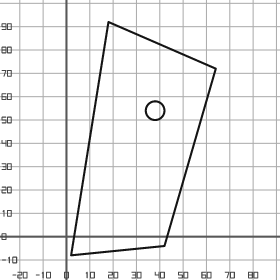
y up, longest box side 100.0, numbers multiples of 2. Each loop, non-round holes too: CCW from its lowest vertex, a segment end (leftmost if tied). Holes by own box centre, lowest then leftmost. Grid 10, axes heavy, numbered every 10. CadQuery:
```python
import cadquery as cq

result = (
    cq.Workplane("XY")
    .moveTo(2.0, -8.0)
    .lineTo(42.0, -4.0)
    .lineTo(64.0, 72.0)
    .lineTo(18.0, 92.0)
    .close()
    .moveTo(38.0, 54.0)
    .circle(4.0)
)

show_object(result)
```